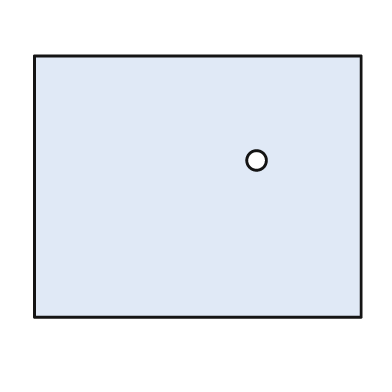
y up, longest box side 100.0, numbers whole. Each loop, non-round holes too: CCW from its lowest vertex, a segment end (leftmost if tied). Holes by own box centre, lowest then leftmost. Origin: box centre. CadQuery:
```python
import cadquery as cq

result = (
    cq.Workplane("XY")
    .moveTo(-50.0, -40.0)
    .lineTo(50.0, -40.0)
    .lineTo(50.0, 40.0)
    .lineTo(-50.0, 40.0)
    .close()
    .moveTo(18.0, 8.0)
    .circle(3.0)
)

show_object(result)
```